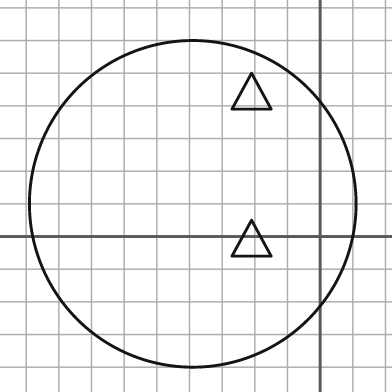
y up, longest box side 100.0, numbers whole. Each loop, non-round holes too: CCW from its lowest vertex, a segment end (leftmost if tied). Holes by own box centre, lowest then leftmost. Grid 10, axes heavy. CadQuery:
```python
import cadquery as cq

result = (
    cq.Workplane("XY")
    .moveTo(-39.0, 10.0)
    .circle(50.0)
    .moveTo(-27.0, -6.0)
    .lineTo(-15.0, -6.0)
    .lineTo(-21.0, 5.0)
    .close()
    .moveTo(-27.0, 39.0)
    .lineTo(-15.0, 39.0)
    .lineTo(-21.0, 50.0)
    .close()
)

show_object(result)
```